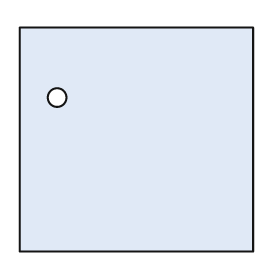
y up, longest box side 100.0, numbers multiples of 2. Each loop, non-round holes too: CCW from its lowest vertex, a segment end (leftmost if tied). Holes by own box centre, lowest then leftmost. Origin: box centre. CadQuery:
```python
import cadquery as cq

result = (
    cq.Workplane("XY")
    .moveTo(-50.0, -48.0)
    .lineTo(50.0, -48.0)
    .lineTo(50.0, 48.0)
    .lineTo(-50.0, 48.0)
    .close()
    .moveTo(-34.0, 18.0)
    .circle(4.0)
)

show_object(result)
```